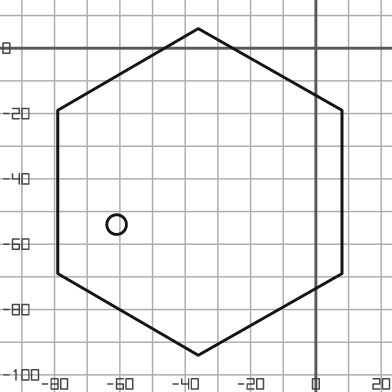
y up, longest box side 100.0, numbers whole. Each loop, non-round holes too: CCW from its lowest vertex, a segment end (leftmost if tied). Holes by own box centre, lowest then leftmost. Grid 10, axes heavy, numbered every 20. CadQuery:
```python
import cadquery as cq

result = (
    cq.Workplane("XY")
    .moveTo(-36.0, -94.0)
    .lineTo(8.0, -69.0)
    .lineTo(8.0, -19.0)
    .lineTo(-36.0, 6.0)
    .lineTo(-79.0, -19.0)
    .lineTo(-79.0, -69.0)
    .close()
    .moveTo(-61.0, -54.0)
    .circle(3.0)
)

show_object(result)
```